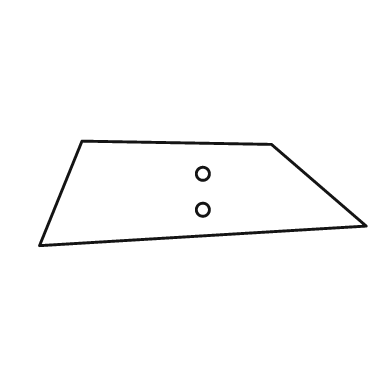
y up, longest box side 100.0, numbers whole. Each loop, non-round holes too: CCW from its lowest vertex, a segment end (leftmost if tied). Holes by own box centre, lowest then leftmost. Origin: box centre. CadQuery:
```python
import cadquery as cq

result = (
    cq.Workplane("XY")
    .moveTo(-50.0, -16.0)
    .lineTo(50.0, -10.0)
    .lineTo(21.0, 15.0)
    .lineTo(-37.0, 16.0)
    .close()
    .moveTo(0.0, -5.0)
    .circle(2.0)
    .moveTo(0.0, 6.0)
    .circle(2.0)
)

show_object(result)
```